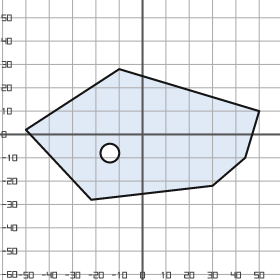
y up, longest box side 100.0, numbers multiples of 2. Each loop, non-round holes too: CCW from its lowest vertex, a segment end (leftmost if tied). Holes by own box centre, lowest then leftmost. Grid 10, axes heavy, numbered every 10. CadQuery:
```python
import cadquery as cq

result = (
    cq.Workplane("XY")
    .moveTo(-22.0, -28.0)
    .lineTo(30.0, -22.0)
    .lineTo(44.0, -10.0)
    .lineTo(50.0, 10.0)
    .lineTo(-10.0, 28.0)
    .lineTo(-50.0, 2.0)
    .close()
    .moveTo(-14.0, -8.0)
    .circle(4.0)
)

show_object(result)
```